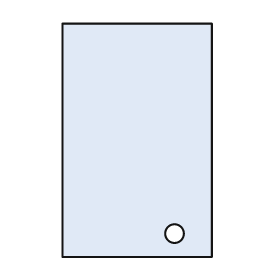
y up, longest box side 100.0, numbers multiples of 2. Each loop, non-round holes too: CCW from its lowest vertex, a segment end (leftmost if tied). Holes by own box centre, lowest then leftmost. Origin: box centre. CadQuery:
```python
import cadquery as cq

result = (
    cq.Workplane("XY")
    .moveTo(-32.0, -50.0)
    .lineTo(32.0, -50.0)
    .lineTo(32.0, 50.0)
    .lineTo(-32.0, 50.0)
    .close()
    .moveTo(16.0, -40.0)
    .circle(4.0)
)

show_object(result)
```